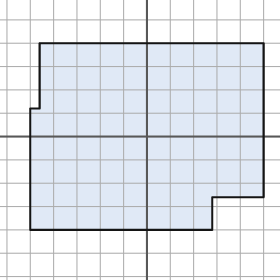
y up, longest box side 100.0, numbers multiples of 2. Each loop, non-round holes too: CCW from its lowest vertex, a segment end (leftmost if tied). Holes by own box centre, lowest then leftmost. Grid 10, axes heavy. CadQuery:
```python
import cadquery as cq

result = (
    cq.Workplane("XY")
    .moveTo(-50.0, -40.0)
    .lineTo(28.0, -40.0)
    .lineTo(28.0, -26.0)
    .lineTo(50.0, -26.0)
    .lineTo(50.0, 40.0)
    .lineTo(-46.0, 40.0)
    .lineTo(-46.0, 12.0)
    .lineTo(-50.0, 12.0)
    .close()
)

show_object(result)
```